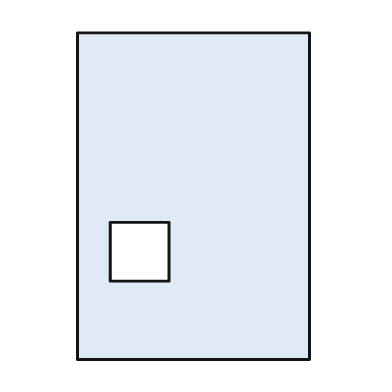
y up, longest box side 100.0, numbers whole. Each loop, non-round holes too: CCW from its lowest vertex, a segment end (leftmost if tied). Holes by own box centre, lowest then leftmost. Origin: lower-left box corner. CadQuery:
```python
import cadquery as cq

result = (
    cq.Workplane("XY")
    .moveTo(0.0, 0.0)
    .lineTo(71.0, 0.0)
    .lineTo(71.0, 100.0)
    .lineTo(0.0, 100.0)
    .close()
    .moveTo(10.0, 24.0)
    .lineTo(28.0, 24.0)
    .lineTo(28.0, 42.0)
    .lineTo(10.0, 42.0)
    .close()
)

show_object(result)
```